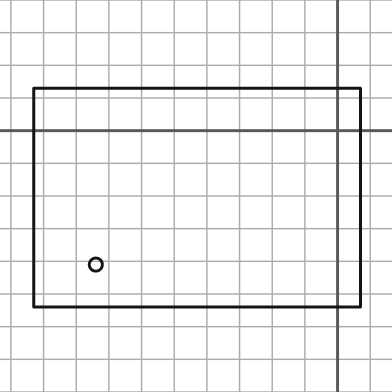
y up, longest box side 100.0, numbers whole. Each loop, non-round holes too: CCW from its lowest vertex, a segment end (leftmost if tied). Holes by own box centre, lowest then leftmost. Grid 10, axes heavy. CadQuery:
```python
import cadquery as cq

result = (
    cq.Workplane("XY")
    .moveTo(-93.0, -54.0)
    .lineTo(7.0, -54.0)
    .lineTo(7.0, 13.0)
    .lineTo(-93.0, 13.0)
    .close()
    .moveTo(-74.0, -41.0)
    .circle(2.0)
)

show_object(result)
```